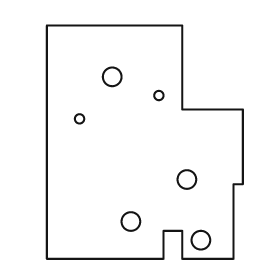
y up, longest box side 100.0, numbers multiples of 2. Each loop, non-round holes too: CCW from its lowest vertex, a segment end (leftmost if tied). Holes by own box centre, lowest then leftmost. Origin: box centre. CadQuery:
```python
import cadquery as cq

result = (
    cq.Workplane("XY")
    .moveTo(-42.0, -50.0)
    .lineTo(8.0, -50.0)
    .lineTo(8.0, -38.0)
    .lineTo(16.0, -38.0)
    .lineTo(16.0, -50.0)
    .lineTo(38.0, -50.0)
    .lineTo(38.0, -18.0)
    .lineTo(42.0, -18.0)
    .lineTo(42.0, 14.0)
    .lineTo(16.0, 14.0)
    .lineTo(16.0, 50.0)
    .lineTo(-42.0, 50.0)
    .close()
    .moveTo(24.0, -42.0)
    .circle(4.0)
    .moveTo(-6.0, -34.0)
    .circle(4.0)
    .moveTo(18.0, -16.0)
    .circle(4.0)
    .moveTo(-28.0, 10.0)
    .circle(2.0)
    .moveTo(6.0, 20.0)
    .circle(2.0)
    .moveTo(-14.0, 28.0)
    .circle(4.0)
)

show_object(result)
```